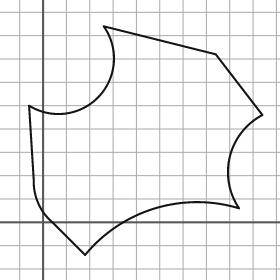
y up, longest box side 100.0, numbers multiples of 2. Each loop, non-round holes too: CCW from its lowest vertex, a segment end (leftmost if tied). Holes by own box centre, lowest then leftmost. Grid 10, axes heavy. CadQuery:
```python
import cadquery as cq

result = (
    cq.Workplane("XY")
    .moveTo(18.0, -14.0)
    .threePointArc((48.0, 6.0), (84.0, 6.0))
    .threePointArc((80.0, 28.0), (94.0, 46.0))
    .lineTo(74.0, 72.0)
    .lineTo(26.0, 84.0)
    .threePointArc((24.0, 54.0), (-6.0, 50.0))
    .lineTo(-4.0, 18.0)
    .threePointArc((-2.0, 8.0), (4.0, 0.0))
    .close()
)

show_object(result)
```